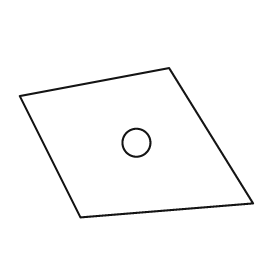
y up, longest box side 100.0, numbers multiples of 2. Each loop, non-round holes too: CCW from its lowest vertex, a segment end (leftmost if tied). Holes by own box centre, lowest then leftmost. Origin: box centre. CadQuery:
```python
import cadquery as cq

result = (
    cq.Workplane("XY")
    .moveTo(-24.0, -32.0)
    .lineTo(50.0, -26.0)
    .lineTo(14.0, 32.0)
    .lineTo(-50.0, 20.0)
    .close()
    .moveTo(0.0, 0.0)
    .circle(6.0)
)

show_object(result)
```